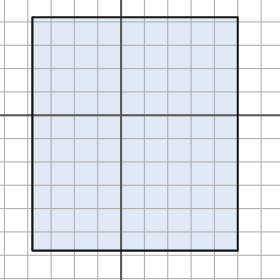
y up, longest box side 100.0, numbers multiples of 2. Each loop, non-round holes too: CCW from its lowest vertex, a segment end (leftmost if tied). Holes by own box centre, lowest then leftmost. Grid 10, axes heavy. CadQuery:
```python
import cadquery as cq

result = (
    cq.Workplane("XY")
    .moveTo(-38.0, -58.0)
    .lineTo(50.0, -58.0)
    .lineTo(50.0, 42.0)
    .lineTo(-38.0, 42.0)
    .close()
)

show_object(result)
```